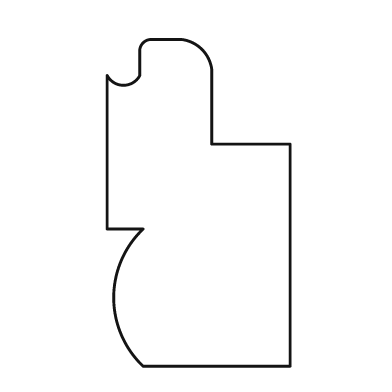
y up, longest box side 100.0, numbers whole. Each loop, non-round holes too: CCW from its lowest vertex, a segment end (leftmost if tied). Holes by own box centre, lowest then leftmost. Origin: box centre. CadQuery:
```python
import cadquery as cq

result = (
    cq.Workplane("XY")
    .moveTo(-17.0, -50.0)
    .lineTo(28.0, -50.0)
    .lineTo(28.0, 18.0)
    .lineTo(4.0, 18.0)
    .lineTo(4.0, 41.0)
    .threePointArc((1.0, 47.0), (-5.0, 50.0))
    .lineTo(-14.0, 50.0)
    .threePointArc((-17.0, 49.0), (-18.0, 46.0))
    .lineTo(-18.0, 39.0)
    .threePointArc((-23.0, 36.0), (-28.0, 39.0))
    .lineTo(-28.0, -8.0)
    .lineTo(-17.0, -8.0)
    .threePointArc((-26.0, -29.0), (-17.0, -50.0))
    .close()
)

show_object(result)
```